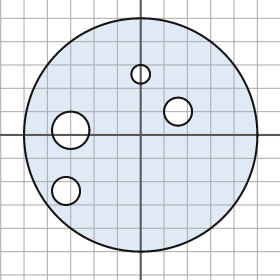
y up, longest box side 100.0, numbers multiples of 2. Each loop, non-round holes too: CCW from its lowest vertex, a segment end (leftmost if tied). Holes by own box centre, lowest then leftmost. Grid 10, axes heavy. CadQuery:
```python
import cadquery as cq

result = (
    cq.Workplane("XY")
    .moveTo(0.0, 0.0)
    .circle(50.0)
    .moveTo(-32.0, -24.0)
    .circle(6.0)
    .moveTo(-30.0, 2.0)
    .circle(8.0)
    .moveTo(16.0, 10.0)
    .circle(6.0)
    .moveTo(0.0, 26.0)
    .circle(4.0)
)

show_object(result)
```